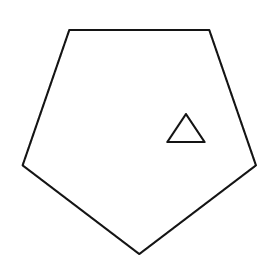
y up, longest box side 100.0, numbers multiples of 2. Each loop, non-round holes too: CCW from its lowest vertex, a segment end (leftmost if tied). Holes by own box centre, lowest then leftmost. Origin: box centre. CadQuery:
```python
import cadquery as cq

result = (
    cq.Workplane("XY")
    .moveTo(0.0, -48.0)
    .lineTo(50.0, -10.0)
    .lineTo(30.0, 48.0)
    .lineTo(-30.0, 48.0)
    .lineTo(-50.0, -10.0)
    .close()
    .moveTo(12.0, 0.0)
    .lineTo(28.0, 0.0)
    .lineTo(20.0, 12.0)
    .close()
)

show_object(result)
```